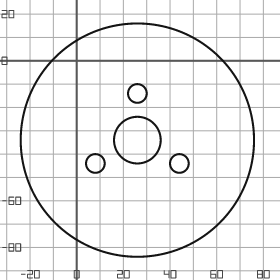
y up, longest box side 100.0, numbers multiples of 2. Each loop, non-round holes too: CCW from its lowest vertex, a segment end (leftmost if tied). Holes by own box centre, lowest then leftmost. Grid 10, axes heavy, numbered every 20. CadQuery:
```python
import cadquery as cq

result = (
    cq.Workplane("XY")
    .moveTo(26.0, -34.0)
    .circle(50.0)
    .moveTo(8.0, -44.0)
    .circle(4.0)
    .moveTo(44.0, -44.0)
    .circle(4.0)
    .moveTo(26.0, -34.0)
    .circle(10.0)
    .moveTo(26.0, -14.0)
    .circle(4.0)
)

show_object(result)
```